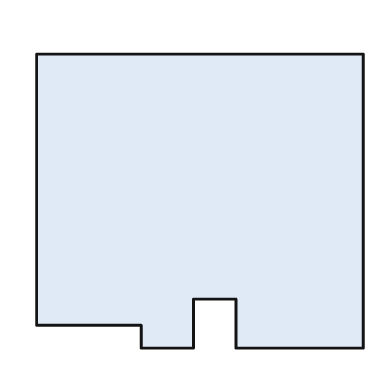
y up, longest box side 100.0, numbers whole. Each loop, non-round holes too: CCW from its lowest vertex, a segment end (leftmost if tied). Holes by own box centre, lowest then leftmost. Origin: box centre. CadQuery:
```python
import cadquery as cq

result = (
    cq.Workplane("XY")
    .moveTo(-18.0, -45.0)
    .lineTo(-2.0, -45.0)
    .lineTo(-2.0, -30.0)
    .lineTo(11.0, -30.0)
    .lineTo(11.0, -45.0)
    .lineTo(50.0, -45.0)
    .lineTo(50.0, 45.0)
    .lineTo(-50.0, 45.0)
    .lineTo(-50.0, -38.0)
    .lineTo(-18.0, -38.0)
    .close()
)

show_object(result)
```